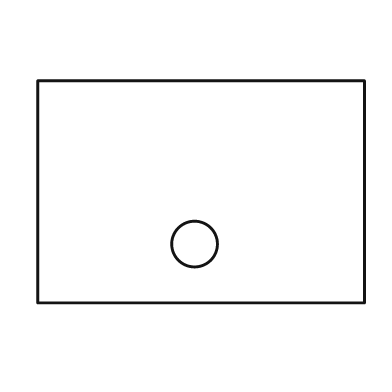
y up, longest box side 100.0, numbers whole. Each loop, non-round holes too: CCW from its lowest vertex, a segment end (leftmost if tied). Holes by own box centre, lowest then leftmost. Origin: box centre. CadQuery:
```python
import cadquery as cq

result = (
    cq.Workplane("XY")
    .moveTo(-50.0, -34.0)
    .lineTo(50.0, -34.0)
    .lineTo(50.0, 34.0)
    .lineTo(-50.0, 34.0)
    .close()
    .moveTo(-2.0, -16.0)
    .circle(7.0)
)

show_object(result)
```